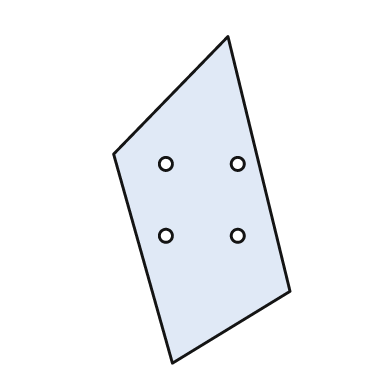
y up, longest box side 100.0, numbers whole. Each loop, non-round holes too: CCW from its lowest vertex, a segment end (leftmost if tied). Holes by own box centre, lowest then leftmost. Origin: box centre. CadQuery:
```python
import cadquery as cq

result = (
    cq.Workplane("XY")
    .moveTo(-9.0, -50.0)
    .lineTo(27.0, -28.0)
    .lineTo(8.0, 50.0)
    .lineTo(-27.0, 14.0)
    .close()
    .moveTo(-11.0, -11.0)
    .circle(2.0)
    .moveTo(11.0, -11.0)
    .circle(2.0)
    .moveTo(-11.0, 11.0)
    .circle(2.0)
    .moveTo(11.0, 11.0)
    .circle(2.0)
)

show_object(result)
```